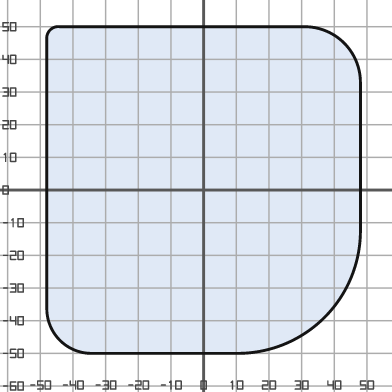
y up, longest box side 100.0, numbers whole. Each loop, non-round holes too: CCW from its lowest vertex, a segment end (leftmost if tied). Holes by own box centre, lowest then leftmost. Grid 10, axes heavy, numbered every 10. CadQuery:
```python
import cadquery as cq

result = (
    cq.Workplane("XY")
    .moveTo(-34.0, -50.0)
    .lineTo(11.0, -50.0)
    .threePointArc((37.0, -39.0), (48.0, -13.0))
    .lineTo(48.0, 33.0)
    .threePointArc((43.0, 45.0), (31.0, 50.0))
    .lineTo(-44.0, 50.0)
    .threePointArc((-47.0, 49.0), (-48.0, 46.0))
    .lineTo(-48.0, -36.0)
    .threePointArc((-44.0, -46.0), (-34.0, -50.0))
    .close()
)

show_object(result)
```